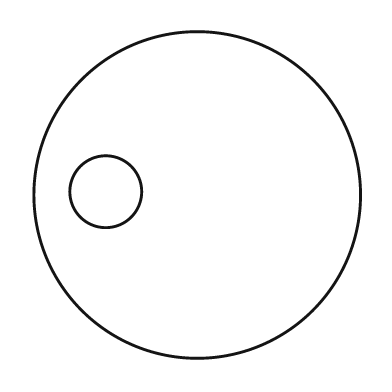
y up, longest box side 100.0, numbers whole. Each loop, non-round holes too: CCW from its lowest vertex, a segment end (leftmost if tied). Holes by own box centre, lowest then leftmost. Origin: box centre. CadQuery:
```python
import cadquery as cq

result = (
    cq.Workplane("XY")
    .moveTo(0.0, 0.0)
    .circle(50.0)
    .moveTo(-28.0, 1.0)
    .circle(11.0)
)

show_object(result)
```